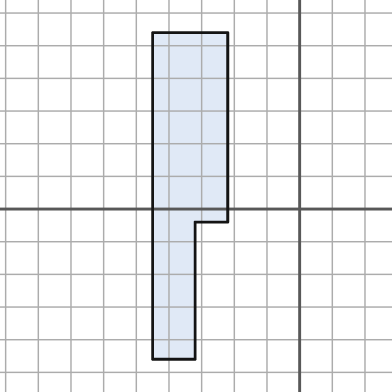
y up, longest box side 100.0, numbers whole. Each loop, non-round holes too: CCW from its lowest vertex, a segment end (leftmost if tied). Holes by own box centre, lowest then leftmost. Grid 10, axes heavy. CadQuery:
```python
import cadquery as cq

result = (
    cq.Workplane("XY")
    .moveTo(-45.0, -46.0)
    .lineTo(-32.0, -46.0)
    .lineTo(-32.0, -4.0)
    .lineTo(-22.0, -4.0)
    .lineTo(-22.0, 54.0)
    .lineTo(-45.0, 54.0)
    .close()
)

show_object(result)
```